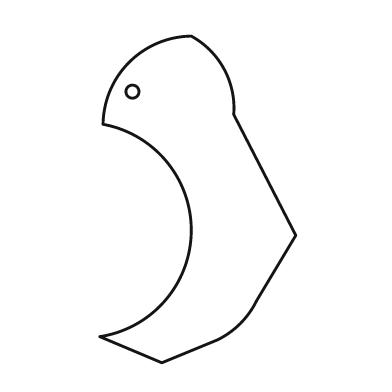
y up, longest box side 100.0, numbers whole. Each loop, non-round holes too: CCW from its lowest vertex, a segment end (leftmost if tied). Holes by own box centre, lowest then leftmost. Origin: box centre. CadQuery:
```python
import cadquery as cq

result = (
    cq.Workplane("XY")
    .moveTo(-11.0, -50.0)
    .lineTo(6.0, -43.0)
    .threePointArc((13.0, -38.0), (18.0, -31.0))
    .lineTo(30.0, -11.0)
    .lineTo(11.0, 26.0)
    .threePointArc((8.0, 40.0), (-2.0, 50.0))
    .threePointArc((-21.0, 42.0), (-29.0, 23.0))
    .threePointArc((-2.0, -10.0), (-30.0, -42.0))
    .close()
    .moveTo(-20.0, 33.0)
    .circle(2.0)
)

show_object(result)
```